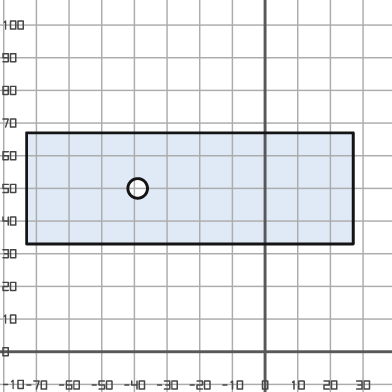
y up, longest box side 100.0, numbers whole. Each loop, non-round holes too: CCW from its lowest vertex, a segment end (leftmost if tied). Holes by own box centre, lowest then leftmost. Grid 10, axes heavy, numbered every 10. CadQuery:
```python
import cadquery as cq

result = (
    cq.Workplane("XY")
    .moveTo(-73.0, 33.0)
    .lineTo(27.0, 33.0)
    .lineTo(27.0, 67.0)
    .lineTo(-73.0, 67.0)
    .close()
    .moveTo(-39.0, 50.0)
    .circle(3.0)
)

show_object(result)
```